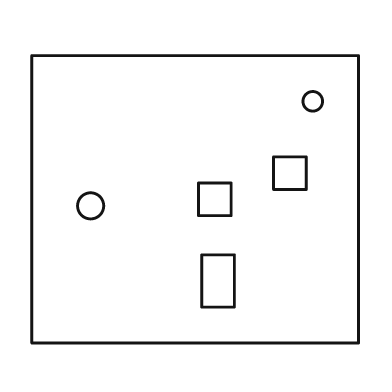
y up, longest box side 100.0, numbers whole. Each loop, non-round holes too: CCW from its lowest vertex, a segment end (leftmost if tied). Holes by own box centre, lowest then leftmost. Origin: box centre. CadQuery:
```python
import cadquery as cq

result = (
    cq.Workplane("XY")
    .moveTo(-50.0, -44.0)
    .lineTo(50.0, -44.0)
    .lineTo(50.0, 44.0)
    .lineTo(-50.0, 44.0)
    .close()
    .moveTo(2.0, -33.0)
    .lineTo(12.0, -33.0)
    .lineTo(12.0, -17.0)
    .lineTo(2.0, -17.0)
    .close()
    .moveTo(-32.0, -2.0)
    .circle(4.0)
    .moveTo(1.0, -5.0)
    .lineTo(11.0, -5.0)
    .lineTo(11.0, 5.0)
    .lineTo(1.0, 5.0)
    .close()
    .moveTo(24.0, 3.0)
    .lineTo(34.0, 3.0)
    .lineTo(34.0, 13.0)
    .lineTo(24.0, 13.0)
    .close()
    .moveTo(36.0, 30.0)
    .circle(3.0)
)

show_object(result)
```